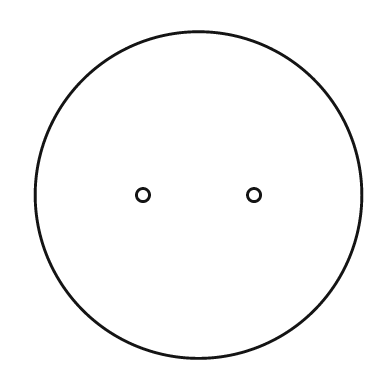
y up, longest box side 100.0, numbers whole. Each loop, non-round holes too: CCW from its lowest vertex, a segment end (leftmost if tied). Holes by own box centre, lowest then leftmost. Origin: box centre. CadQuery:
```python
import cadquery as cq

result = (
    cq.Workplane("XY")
    .moveTo(0.0, 0.0)
    .circle(50.0)
    .moveTo(-17.0, 0.0)
    .circle(2.0)
    .moveTo(17.0, 0.0)
    .circle(2.0)
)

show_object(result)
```